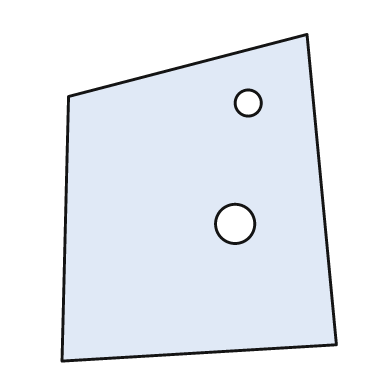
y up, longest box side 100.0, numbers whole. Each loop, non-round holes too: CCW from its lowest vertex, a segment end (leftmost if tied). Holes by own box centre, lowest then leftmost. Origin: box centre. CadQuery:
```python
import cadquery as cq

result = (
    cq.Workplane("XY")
    .moveTo(-42.0, -50.0)
    .lineTo(42.0, -45.0)
    .lineTo(33.0, 50.0)
    .lineTo(-40.0, 31.0)
    .close()
    .moveTo(11.0, -8.0)
    .circle(6.0)
    .moveTo(15.0, 29.0)
    .circle(4.0)
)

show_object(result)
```